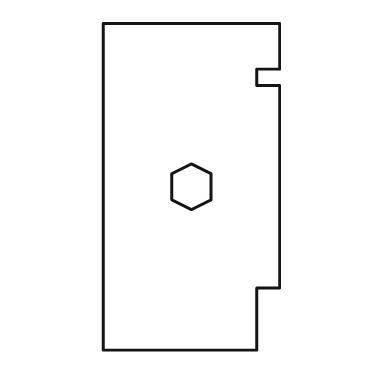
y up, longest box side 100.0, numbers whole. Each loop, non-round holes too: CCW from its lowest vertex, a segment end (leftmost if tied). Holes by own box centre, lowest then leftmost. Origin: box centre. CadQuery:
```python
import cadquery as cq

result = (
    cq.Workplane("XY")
    .moveTo(-27.0, -50.0)
    .lineTo(20.0, -50.0)
    .lineTo(20.0, -31.0)
    .lineTo(27.0, -31.0)
    .lineTo(27.0, 31.0)
    .lineTo(20.0, 31.0)
    .lineTo(20.0, 36.0)
    .lineTo(27.0, 36.0)
    .lineTo(27.0, 50.0)
    .lineTo(-27.0, 50.0)
    .close()
    .moveTo(0.0, -7.0)
    .lineTo(6.0, -4.0)
    .lineTo(6.0, 4.0)
    .lineTo(0.0, 7.0)
    .lineTo(-6.0, 4.0)
    .lineTo(-6.0, -4.0)
    .close()
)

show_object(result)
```